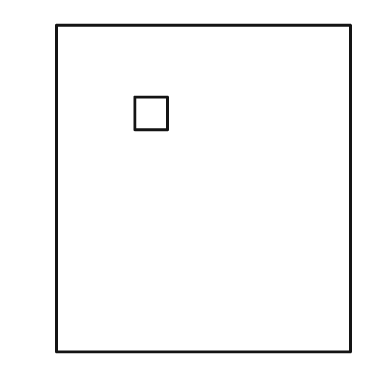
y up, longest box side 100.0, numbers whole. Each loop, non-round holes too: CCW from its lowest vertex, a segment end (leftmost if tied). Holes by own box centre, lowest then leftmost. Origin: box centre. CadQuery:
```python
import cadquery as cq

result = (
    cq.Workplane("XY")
    .moveTo(-45.0, -50.0)
    .lineTo(45.0, -50.0)
    .lineTo(45.0, 50.0)
    .lineTo(-45.0, 50.0)
    .close()
    .moveTo(-21.0, 18.0)
    .lineTo(-11.0, 18.0)
    .lineTo(-11.0, 28.0)
    .lineTo(-21.0, 28.0)
    .close()
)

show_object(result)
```